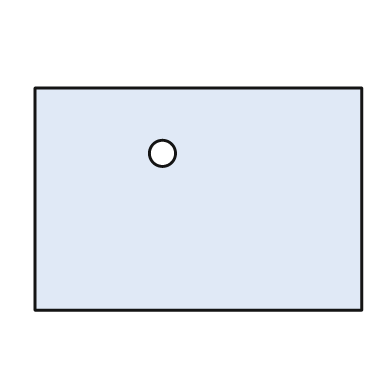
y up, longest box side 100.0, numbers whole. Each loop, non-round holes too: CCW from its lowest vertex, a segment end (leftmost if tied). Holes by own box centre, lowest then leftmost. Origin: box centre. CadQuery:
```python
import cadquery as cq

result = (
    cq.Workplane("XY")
    .moveTo(-50.0, -34.0)
    .lineTo(50.0, -34.0)
    .lineTo(50.0, 34.0)
    .lineTo(-50.0, 34.0)
    .close()
    .moveTo(-11.0, 14.0)
    .circle(4.0)
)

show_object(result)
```